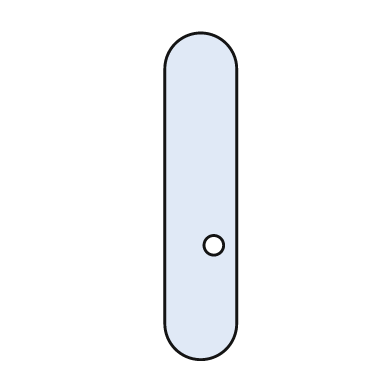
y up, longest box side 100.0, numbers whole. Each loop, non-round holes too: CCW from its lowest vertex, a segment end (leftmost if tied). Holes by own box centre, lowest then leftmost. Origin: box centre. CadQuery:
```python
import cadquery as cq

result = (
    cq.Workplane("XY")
    .moveTo(-11.0, -39.0)
    .threePointArc((0.0, -50.0), (11.0, -39.0))
    .lineTo(11.0, 39.0)
    .threePointArc((0.0, 50.0), (-11.0, 39.0))
    .close()
    .moveTo(4.0, -15.0)
    .circle(3.0)
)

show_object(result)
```